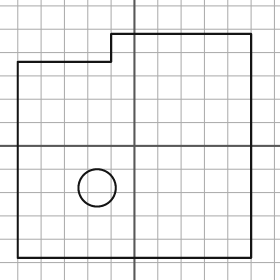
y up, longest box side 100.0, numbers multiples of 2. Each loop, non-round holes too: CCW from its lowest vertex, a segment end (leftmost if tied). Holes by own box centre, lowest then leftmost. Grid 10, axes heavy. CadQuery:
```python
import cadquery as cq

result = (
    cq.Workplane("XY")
    .moveTo(-50.0, -48.0)
    .lineTo(50.0, -48.0)
    .lineTo(50.0, 48.0)
    .lineTo(-10.0, 48.0)
    .lineTo(-10.0, 36.0)
    .lineTo(-50.0, 36.0)
    .close()
    .moveTo(-16.0, -18.0)
    .circle(8.0)
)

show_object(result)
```